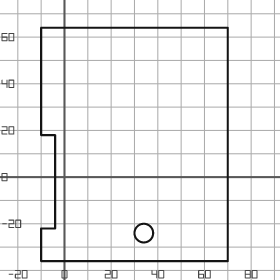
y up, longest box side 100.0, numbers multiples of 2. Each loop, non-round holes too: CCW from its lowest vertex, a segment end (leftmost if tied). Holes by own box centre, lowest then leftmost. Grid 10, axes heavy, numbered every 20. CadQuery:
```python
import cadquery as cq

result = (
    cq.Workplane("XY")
    .moveTo(-10.0, -36.0)
    .lineTo(70.0, -36.0)
    .lineTo(70.0, 64.0)
    .lineTo(-10.0, 64.0)
    .lineTo(-10.0, 18.0)
    .lineTo(-4.0, 18.0)
    .lineTo(-4.0, -22.0)
    .lineTo(-10.0, -22.0)
    .close()
    .moveTo(34.0, -24.0)
    .circle(4.0)
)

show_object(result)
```